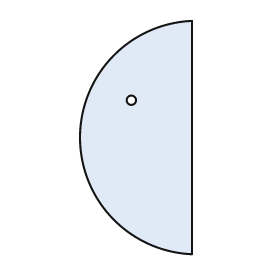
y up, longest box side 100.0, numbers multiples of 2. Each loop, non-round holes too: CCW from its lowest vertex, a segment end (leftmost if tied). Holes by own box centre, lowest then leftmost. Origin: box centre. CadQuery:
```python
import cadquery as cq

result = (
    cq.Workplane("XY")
    .moveTo(24.0, -50.0)
    .lineTo(24.0, 50.0)
    .threePointArc((-24.0, 0.0), (24.0, -50.0))
    .close()
    .moveTo(-2.0, 16.0)
    .circle(2.0)
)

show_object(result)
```